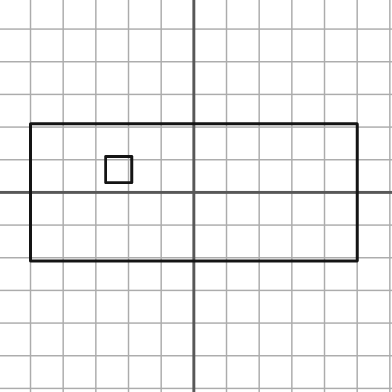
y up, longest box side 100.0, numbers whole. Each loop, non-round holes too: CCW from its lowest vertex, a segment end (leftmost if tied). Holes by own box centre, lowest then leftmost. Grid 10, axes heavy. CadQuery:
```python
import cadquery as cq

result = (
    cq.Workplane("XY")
    .moveTo(-50.0, -21.0)
    .lineTo(50.0, -21.0)
    .lineTo(50.0, 21.0)
    .lineTo(-50.0, 21.0)
    .close()
    .moveTo(-27.0, 3.0)
    .lineTo(-19.0, 3.0)
    .lineTo(-19.0, 11.0)
    .lineTo(-27.0, 11.0)
    .close()
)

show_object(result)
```